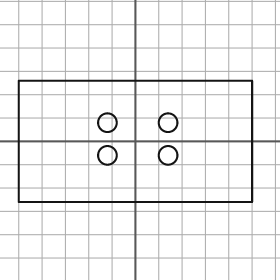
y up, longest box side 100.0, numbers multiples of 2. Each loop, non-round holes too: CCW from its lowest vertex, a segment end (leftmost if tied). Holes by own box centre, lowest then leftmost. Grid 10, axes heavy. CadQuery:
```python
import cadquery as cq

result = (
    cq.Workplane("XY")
    .moveTo(-50.0, -26.0)
    .lineTo(50.0, -26.0)
    .lineTo(50.0, 26.0)
    .lineTo(-50.0, 26.0)
    .close()
    .moveTo(-12.0, -6.0)
    .circle(4.0)
    .moveTo(14.0, -6.0)
    .circle(4.0)
    .moveTo(-12.0, 8.0)
    .circle(4.0)
    .moveTo(14.0, 8.0)
    .circle(4.0)
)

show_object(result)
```